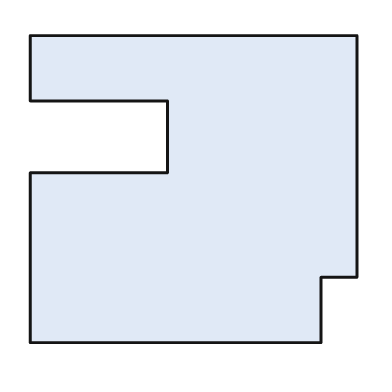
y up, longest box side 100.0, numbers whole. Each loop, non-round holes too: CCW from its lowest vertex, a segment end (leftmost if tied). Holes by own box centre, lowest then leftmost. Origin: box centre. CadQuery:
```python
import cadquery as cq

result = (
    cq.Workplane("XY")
    .moveTo(-50.0, -47.0)
    .lineTo(39.0, -47.0)
    .lineTo(39.0, -27.0)
    .lineTo(50.0, -27.0)
    .lineTo(50.0, 47.0)
    .lineTo(-50.0, 47.0)
    .lineTo(-50.0, 27.0)
    .lineTo(-8.0, 27.0)
    .lineTo(-8.0, 5.0)
    .lineTo(-50.0, 5.0)
    .close()
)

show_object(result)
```